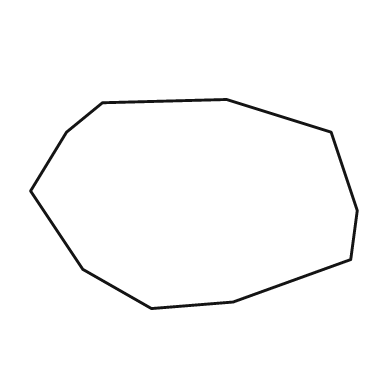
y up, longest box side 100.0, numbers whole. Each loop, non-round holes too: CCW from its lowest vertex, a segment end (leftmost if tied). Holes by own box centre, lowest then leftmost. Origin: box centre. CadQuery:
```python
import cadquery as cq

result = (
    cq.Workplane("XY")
    .moveTo(-13.0, -32.0)
    .lineTo(12.0, -30.0)
    .lineTo(48.0, -17.0)
    .lineTo(50.0, -2.0)
    .lineTo(42.0, 22.0)
    .lineTo(10.0, 32.0)
    .lineTo(-28.0, 31.0)
    .lineTo(-39.0, 22.0)
    .lineTo(-50.0, 4.0)
    .lineTo(-34.0, -20.0)
    .close()
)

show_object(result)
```